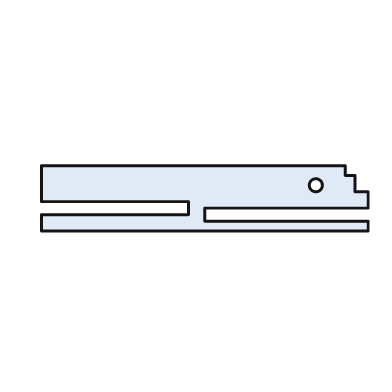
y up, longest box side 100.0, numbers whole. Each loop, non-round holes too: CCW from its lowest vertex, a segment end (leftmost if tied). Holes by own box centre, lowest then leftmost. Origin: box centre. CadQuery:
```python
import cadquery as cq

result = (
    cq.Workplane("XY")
    .moveTo(-50.0, -10.0)
    .lineTo(50.0, -10.0)
    .lineTo(50.0, -7.0)
    .lineTo(0.0, -7.0)
    .lineTo(0.0, -3.0)
    .lineTo(50.0, -3.0)
    .lineTo(50.0, 2.0)
    .lineTo(46.0, 2.0)
    .lineTo(46.0, 7.0)
    .lineTo(43.0, 7.0)
    .lineTo(43.0, 10.0)
    .lineTo(-50.0, 10.0)
    .lineTo(-50.0, -1.0)
    .lineTo(-5.0, -1.0)
    .lineTo(-5.0, -5.0)
    .lineTo(-50.0, -5.0)
    .close()
    .moveTo(34.0, 4.0)
    .circle(2.0)
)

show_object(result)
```